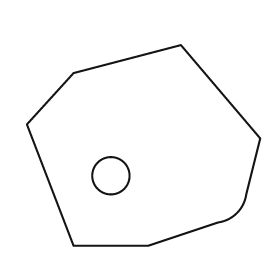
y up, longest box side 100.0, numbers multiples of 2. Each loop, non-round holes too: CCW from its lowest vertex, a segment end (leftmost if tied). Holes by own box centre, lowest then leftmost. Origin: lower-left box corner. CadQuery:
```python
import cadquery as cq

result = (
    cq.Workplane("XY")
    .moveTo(20.0, 0.0)
    .lineTo(52.0, 0.0)
    .lineTo(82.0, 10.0)
    .threePointArc((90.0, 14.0), (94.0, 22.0))
    .lineTo(100.0, 46.0)
    .lineTo(66.0, 86.0)
    .lineTo(20.0, 74.0)
    .lineTo(0.0, 52.0)
    .close()
    .moveTo(36.0, 30.0)
    .circle(8.0)
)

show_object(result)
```